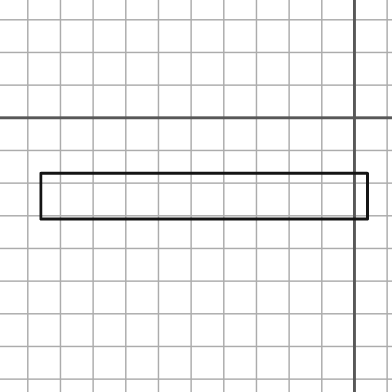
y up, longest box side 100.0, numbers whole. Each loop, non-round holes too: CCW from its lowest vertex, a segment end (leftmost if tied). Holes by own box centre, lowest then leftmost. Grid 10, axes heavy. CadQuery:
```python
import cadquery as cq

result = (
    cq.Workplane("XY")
    .moveTo(-96.0, -31.0)
    .lineTo(4.0, -31.0)
    .lineTo(4.0, -17.0)
    .lineTo(-96.0, -17.0)
    .close()
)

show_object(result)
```